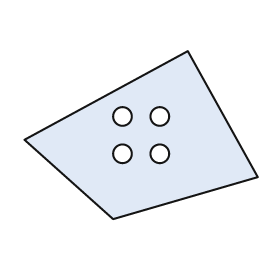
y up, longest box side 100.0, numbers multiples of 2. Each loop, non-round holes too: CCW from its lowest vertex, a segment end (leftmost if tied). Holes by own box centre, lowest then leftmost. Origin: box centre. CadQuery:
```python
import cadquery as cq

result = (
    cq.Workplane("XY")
    .moveTo(-12.0, -36.0)
    .lineTo(50.0, -18.0)
    .lineTo(20.0, 36.0)
    .lineTo(-50.0, -2.0)
    .close()
    .moveTo(-8.0, -8.0)
    .circle(4.0)
    .moveTo(8.0, -8.0)
    .circle(4.0)
    .moveTo(-8.0, 8.0)
    .circle(4.0)
    .moveTo(8.0, 8.0)
    .circle(4.0)
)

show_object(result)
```